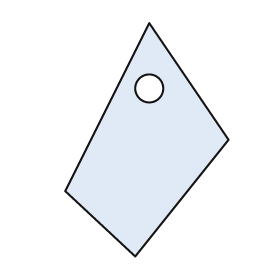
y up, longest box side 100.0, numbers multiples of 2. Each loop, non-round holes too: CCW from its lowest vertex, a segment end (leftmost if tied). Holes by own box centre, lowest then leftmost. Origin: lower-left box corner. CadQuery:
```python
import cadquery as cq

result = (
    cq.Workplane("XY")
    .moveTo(30.0, 0.0)
    .lineTo(70.0, 50.0)
    .lineTo(36.0, 100.0)
    .lineTo(0.0, 28.0)
    .close()
    .moveTo(36.0, 72.0)
    .circle(6.0)
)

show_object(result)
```